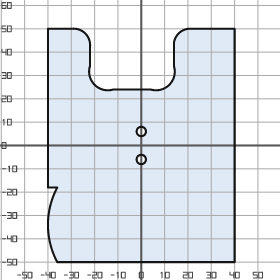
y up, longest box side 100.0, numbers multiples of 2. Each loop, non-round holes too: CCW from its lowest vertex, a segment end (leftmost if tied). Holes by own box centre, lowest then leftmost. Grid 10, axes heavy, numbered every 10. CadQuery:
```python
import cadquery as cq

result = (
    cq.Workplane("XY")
    .moveTo(-36.0, -50.0)
    .lineTo(40.0, -50.0)
    .lineTo(40.0, 50.0)
    .lineTo(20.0, 50.0)
    .threePointArc((16.0, 48.0), (14.0, 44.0))
    .lineTo(14.0, 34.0)
    .threePointArc((12.0, 26.0), (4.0, 24.0))
    .lineTo(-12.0, 24.0)
    .threePointArc((-20.0, 26.0), (-22.0, 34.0))
    .lineTo(-22.0, 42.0)
    .threePointArc((-24.0, 48.0), (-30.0, 50.0))
    .lineTo(-40.0, 50.0)
    .lineTo(-40.0, -18.0)
    .lineTo(-36.0, -18.0)
    .threePointArc((-40.0, -34.0), (-36.0, -50.0))
    .close()
    .moveTo(0.0, -6.0)
    .circle(2.0)
    .moveTo(0.0, 6.0)
    .circle(2.0)
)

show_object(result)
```